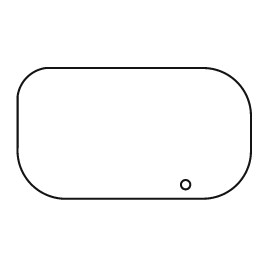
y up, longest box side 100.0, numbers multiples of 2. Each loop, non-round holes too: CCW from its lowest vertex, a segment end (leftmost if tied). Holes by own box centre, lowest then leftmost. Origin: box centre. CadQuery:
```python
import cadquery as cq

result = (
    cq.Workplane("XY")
    .moveTo(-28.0, -28.0)
    .lineTo(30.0, -28.0)
    .threePointArc((44.0, -22.0), (50.0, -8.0))
    .lineTo(50.0, 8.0)
    .threePointArc((44.0, 22.0), (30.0, 28.0))
    .lineTo(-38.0, 28.0)
    .threePointArc((-46.0, 24.0), (-50.0, 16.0))
    .lineTo(-50.0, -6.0)
    .threePointArc((-44.0, -22.0), (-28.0, -28.0))
    .close()
    .moveTo(22.0, -22.0)
    .circle(2.0)
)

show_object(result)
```